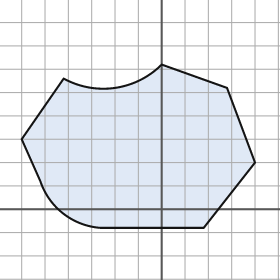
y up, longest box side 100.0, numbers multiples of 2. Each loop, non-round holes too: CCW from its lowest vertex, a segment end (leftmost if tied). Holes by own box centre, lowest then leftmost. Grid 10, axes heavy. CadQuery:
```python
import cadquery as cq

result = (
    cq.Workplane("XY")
    .moveTo(-26.0, -8.0)
    .lineTo(18.0, -8.0)
    .lineTo(40.0, 20.0)
    .lineTo(28.0, 52.0)
    .lineTo(0.0, 62.0)
    .threePointArc((-20.0, 52.0), (-42.0, 56.0))
    .lineTo(-60.0, 30.0)
    .lineTo(-52.0, 12.0)
    .threePointArc((-42.0, -2.0), (-26.0, -8.0))
    .close()
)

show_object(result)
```